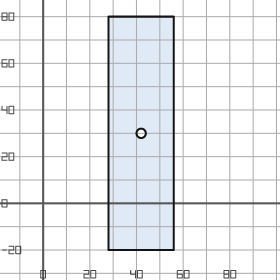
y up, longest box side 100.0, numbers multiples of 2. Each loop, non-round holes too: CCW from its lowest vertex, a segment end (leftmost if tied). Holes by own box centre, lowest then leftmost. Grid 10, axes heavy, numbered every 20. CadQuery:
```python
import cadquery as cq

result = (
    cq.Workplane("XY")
    .moveTo(28.0, -20.0)
    .lineTo(56.0, -20.0)
    .lineTo(56.0, 80.0)
    .lineTo(28.0, 80.0)
    .close()
    .moveTo(42.0, 30.0)
    .circle(2.0)
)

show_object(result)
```